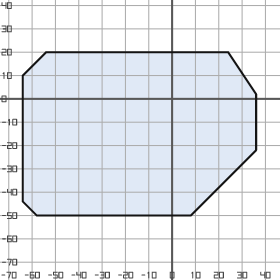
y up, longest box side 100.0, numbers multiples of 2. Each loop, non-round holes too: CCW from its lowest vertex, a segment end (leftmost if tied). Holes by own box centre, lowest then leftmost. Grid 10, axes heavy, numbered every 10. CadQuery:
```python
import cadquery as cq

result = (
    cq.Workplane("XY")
    .moveTo(-58.0, -50.0)
    .lineTo(8.0, -50.0)
    .lineTo(36.0, -22.0)
    .lineTo(36.0, 2.0)
    .lineTo(24.0, 20.0)
    .lineTo(-54.0, 20.0)
    .lineTo(-64.0, 10.0)
    .lineTo(-64.0, -44.0)
    .close()
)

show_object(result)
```